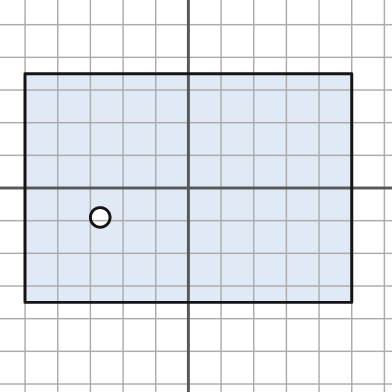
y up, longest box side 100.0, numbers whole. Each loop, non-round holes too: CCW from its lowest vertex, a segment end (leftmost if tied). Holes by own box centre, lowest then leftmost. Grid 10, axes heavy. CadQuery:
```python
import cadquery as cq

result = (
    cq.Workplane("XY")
    .moveTo(-50.0, -35.0)
    .lineTo(50.0, -35.0)
    .lineTo(50.0, 35.0)
    .lineTo(-50.0, 35.0)
    .close()
    .moveTo(-27.0, -9.0)
    .circle(3.0)
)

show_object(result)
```